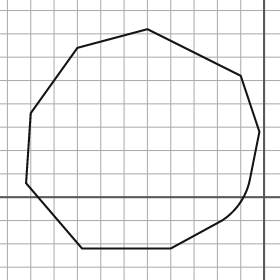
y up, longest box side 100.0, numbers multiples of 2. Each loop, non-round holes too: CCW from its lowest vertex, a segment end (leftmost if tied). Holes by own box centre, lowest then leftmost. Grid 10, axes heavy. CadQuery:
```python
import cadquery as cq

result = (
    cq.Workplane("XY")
    .moveTo(-78.0, -22.0)
    .lineTo(-40.0, -22.0)
    .lineTo(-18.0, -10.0)
    .threePointArc((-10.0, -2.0), (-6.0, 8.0))
    .lineTo(-2.0, 28.0)
    .lineTo(-10.0, 52.0)
    .lineTo(-50.0, 72.0)
    .lineTo(-80.0, 64.0)
    .lineTo(-100.0, 36.0)
    .lineTo(-102.0, 6.0)
    .close()
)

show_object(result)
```